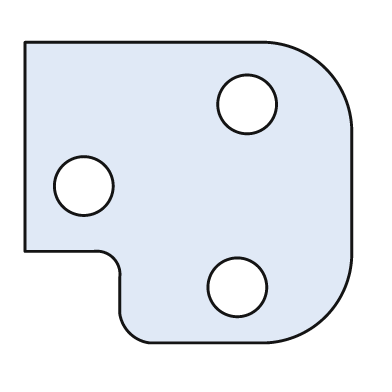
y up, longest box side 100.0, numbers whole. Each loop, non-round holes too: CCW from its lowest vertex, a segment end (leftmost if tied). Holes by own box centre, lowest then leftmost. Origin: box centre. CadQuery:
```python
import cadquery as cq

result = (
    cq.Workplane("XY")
    .moveTo(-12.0, -46.0)
    .lineTo(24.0, -46.0)
    .threePointArc((42.0, -38.0), (50.0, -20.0))
    .lineTo(50.0, 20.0)
    .threePointArc((42.0, 38.0), (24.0, 46.0))
    .lineTo(-50.0, 46.0)
    .lineTo(-50.0, -18.0)
    .lineTo(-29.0, -18.0)
    .threePointArc((-23.0, -20.0), (-21.0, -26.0))
    .lineTo(-21.0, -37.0)
    .threePointArc((-18.0, -43.0), (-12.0, -46.0))
    .close()
    .moveTo(15.0, -29.0)
    .circle(9.0)
    .moveTo(-32.0, 2.0)
    .circle(9.0)
    .moveTo(18.0, 27.0)
    .circle(9.0)
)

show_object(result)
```